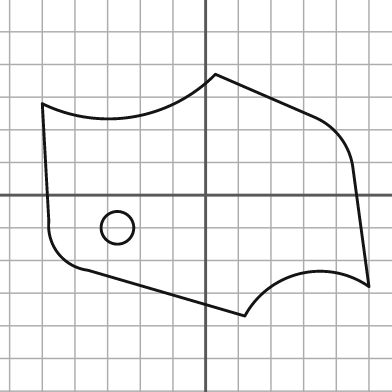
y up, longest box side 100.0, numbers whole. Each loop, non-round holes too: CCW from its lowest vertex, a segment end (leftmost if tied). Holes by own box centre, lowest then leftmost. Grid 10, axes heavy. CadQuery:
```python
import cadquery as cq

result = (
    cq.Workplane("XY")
    .moveTo(12.0, -37.0)
    .threePointArc((29.0, -24.0), (50.0, -28.0))
    .lineTo(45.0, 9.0)
    .threePointArc((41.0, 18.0), (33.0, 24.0))
    .lineTo(3.0, 37.0)
    .threePointArc((-22.0, 24.0), (-50.0, 28.0))
    .lineTo(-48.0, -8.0)
    .threePointArc((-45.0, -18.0), (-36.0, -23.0))
    .close()
    .moveTo(-27.0, -10.0)
    .circle(5.0)
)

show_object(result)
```